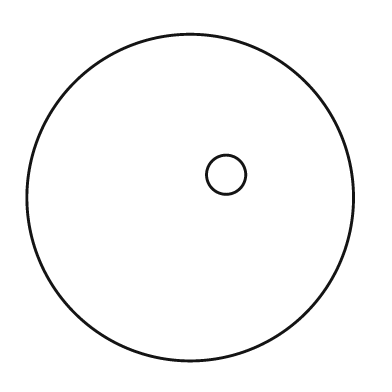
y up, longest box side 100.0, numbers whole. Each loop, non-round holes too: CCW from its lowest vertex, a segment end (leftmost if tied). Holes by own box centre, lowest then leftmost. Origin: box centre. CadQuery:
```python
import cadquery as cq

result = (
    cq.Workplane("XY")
    .moveTo(0.0, 0.0)
    .circle(50.0)
    .moveTo(11.0, 7.0)
    .circle(6.0)
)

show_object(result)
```